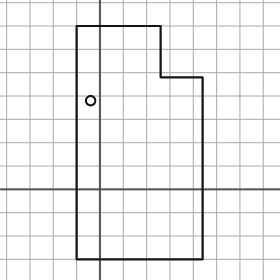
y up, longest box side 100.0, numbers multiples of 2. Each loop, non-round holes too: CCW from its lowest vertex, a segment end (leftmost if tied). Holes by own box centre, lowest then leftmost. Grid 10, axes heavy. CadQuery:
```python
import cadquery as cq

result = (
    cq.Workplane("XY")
    .moveTo(-10.0, -30.0)
    .lineTo(44.0, -30.0)
    .lineTo(44.0, 48.0)
    .lineTo(26.0, 48.0)
    .lineTo(26.0, 70.0)
    .lineTo(-10.0, 70.0)
    .close()
    .moveTo(-4.0, 38.0)
    .circle(2.0)
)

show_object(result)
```